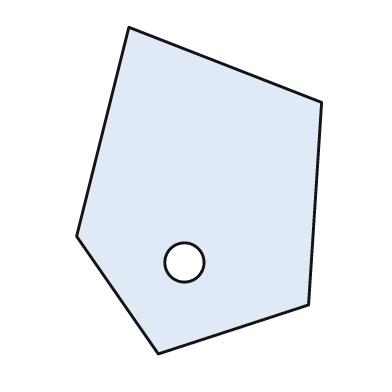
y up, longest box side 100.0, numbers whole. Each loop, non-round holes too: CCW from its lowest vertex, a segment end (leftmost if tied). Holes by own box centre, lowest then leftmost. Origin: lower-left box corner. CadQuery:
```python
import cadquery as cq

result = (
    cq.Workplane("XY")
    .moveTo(25.0, 0.0)
    .lineTo(71.0, 15.0)
    .lineTo(75.0, 77.0)
    .lineTo(16.0, 100.0)
    .lineTo(0.0, 36.0)
    .close()
    .moveTo(33.0, 28.0)
    .circle(6.0)
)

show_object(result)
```